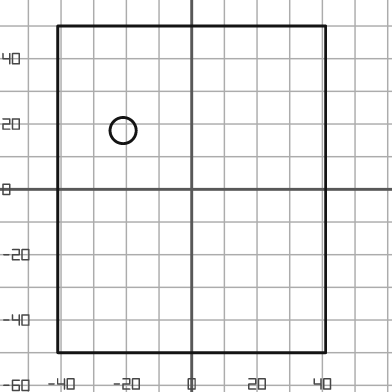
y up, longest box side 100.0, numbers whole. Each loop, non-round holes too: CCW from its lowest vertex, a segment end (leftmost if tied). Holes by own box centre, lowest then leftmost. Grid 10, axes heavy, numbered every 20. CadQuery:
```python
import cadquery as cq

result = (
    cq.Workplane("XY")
    .moveTo(-41.0, -50.0)
    .lineTo(41.0, -50.0)
    .lineTo(41.0, 50.0)
    .lineTo(-41.0, 50.0)
    .close()
    .moveTo(-21.0, 18.0)
    .circle(4.0)
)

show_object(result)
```